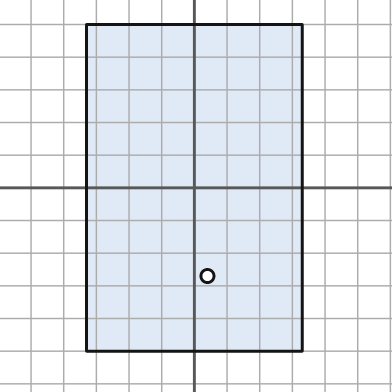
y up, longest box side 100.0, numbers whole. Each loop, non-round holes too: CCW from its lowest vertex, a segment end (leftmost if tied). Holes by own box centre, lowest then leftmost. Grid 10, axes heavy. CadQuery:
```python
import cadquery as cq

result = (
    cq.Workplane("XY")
    .moveTo(-33.0, -50.0)
    .lineTo(33.0, -50.0)
    .lineTo(33.0, 50.0)
    .lineTo(-33.0, 50.0)
    .close()
    .moveTo(4.0, -27.0)
    .circle(2.0)
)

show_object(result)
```